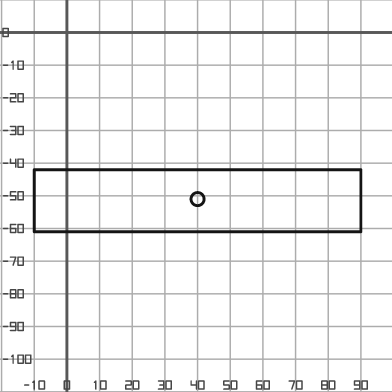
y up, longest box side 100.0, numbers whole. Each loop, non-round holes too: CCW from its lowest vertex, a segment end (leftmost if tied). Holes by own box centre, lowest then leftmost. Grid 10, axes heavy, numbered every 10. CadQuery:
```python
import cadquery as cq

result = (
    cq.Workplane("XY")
    .moveTo(-10.0, -61.0)
    .lineTo(90.0, -61.0)
    .lineTo(90.0, -42.0)
    .lineTo(-10.0, -42.0)
    .close()
    .moveTo(40.0, -51.0)
    .circle(2.0)
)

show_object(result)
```